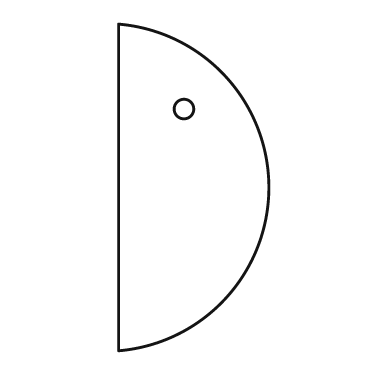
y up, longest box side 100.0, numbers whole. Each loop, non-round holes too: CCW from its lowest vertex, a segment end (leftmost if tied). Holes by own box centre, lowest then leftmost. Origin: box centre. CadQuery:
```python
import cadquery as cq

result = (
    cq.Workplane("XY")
    .moveTo(-23.0, -50.0)
    .threePointArc((23.0, 0.0), (-23.0, 50.0))
    .close()
    .moveTo(-3.0, 24.0)
    .circle(3.0)
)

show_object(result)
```